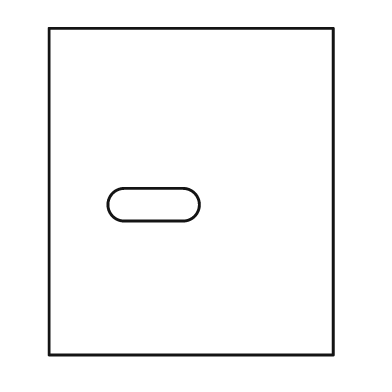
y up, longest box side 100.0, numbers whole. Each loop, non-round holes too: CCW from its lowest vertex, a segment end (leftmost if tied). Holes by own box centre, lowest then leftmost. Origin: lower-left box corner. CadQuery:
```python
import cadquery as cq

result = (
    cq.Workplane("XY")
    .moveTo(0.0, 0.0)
    .lineTo(87.0, 0.0)
    .lineTo(87.0, 100.0)
    .lineTo(0.0, 100.0)
    .close()
    .moveTo(23.0, 41.0)
    .lineTo(41.0, 41.0)
    .threePointArc((46.0, 46.0), (41.0, 51.0))
    .lineTo(23.0, 51.0)
    .threePointArc((18.0, 46.0), (23.0, 41.0))
    .close()
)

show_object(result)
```